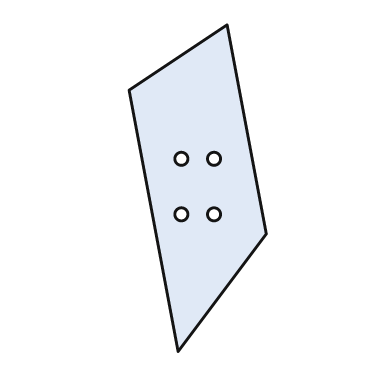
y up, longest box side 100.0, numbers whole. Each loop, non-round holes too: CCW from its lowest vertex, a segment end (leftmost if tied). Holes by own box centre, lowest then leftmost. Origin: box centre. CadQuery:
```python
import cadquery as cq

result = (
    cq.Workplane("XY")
    .moveTo(-6.0, -50.0)
    .lineTo(21.0, -14.0)
    .lineTo(9.0, 50.0)
    .lineTo(-21.0, 30.0)
    .close()
    .moveTo(-5.0, -8.0)
    .circle(2.0)
    .moveTo(5.0, -8.0)
    .circle(2.0)
    .moveTo(-5.0, 9.0)
    .circle(2.0)
    .moveTo(5.0, 9.0)
    .circle(2.0)
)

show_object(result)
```